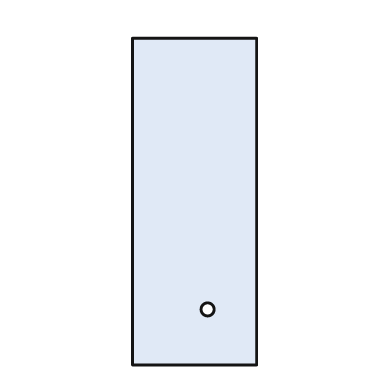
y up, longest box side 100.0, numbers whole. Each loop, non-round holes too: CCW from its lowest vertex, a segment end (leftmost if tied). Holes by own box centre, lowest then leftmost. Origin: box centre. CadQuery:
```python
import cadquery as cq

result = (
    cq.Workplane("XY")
    .moveTo(-19.0, -50.0)
    .lineTo(19.0, -50.0)
    .lineTo(19.0, 50.0)
    .lineTo(-19.0, 50.0)
    .close()
    .moveTo(4.0, -33.0)
    .circle(2.0)
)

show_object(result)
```